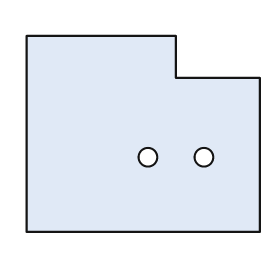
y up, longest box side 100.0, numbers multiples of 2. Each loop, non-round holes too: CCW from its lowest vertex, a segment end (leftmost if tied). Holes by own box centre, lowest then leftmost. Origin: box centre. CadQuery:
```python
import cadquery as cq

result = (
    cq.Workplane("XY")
    .moveTo(-50.0, -42.0)
    .lineTo(50.0, -42.0)
    .lineTo(50.0, 24.0)
    .lineTo(14.0, 24.0)
    .lineTo(14.0, 42.0)
    .lineTo(-50.0, 42.0)
    .close()
    .moveTo(2.0, -10.0)
    .circle(4.0)
    .moveTo(26.0, -10.0)
    .circle(4.0)
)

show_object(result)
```